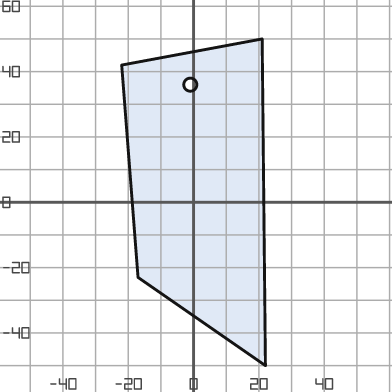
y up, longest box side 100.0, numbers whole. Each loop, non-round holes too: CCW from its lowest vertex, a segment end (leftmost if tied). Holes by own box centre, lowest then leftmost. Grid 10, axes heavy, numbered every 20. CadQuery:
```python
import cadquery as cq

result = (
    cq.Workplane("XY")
    .moveTo(22.0, -50.0)
    .lineTo(21.0, 50.0)
    .lineTo(-22.0, 42.0)
    .lineTo(-17.0, -23.0)
    .close()
    .moveTo(-1.0, 36.0)
    .circle(2.0)
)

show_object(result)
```